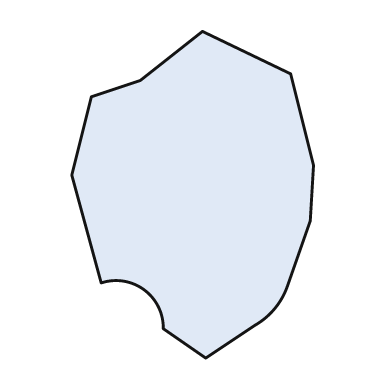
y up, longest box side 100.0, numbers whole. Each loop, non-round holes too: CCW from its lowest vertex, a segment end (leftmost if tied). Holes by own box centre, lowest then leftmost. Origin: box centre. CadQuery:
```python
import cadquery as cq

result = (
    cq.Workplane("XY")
    .moveTo(4.0, -50.0)
    .lineTo(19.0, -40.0)
    .threePointArc((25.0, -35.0), (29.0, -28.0))
    .lineTo(36.0, -8.0)
    .lineTo(37.0, 9.0)
    .lineTo(30.0, 37.0)
    .lineTo(3.0, 50.0)
    .lineTo(-16.0, 35.0)
    .lineTo(-31.0, 30.0)
    .lineTo(-37.0, 6.0)
    .lineTo(-28.0, -27.0)
    .threePointArc((-15.0, -29.0), (-9.0, -41.0))
    .close()
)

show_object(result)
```